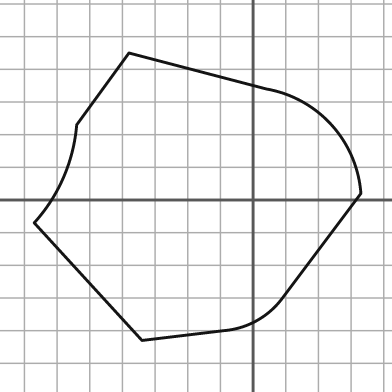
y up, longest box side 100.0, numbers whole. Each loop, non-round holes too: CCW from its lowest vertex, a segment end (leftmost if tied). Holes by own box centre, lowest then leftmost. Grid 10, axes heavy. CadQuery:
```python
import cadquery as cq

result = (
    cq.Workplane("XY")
    .moveTo(-34.0, -43.0)
    .lineTo(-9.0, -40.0)
    .threePointArc((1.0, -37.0), (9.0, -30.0))
    .lineTo(33.0, 2.0)
    .threePointArc((24.0, 23.0), (4.0, 34.0))
    .lineTo(-38.0, 45.0)
    .lineTo(-54.0, 23.0)
    .threePointArc((-58.0, 7.0), (-67.0, -7.0))
    .close()
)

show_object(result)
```